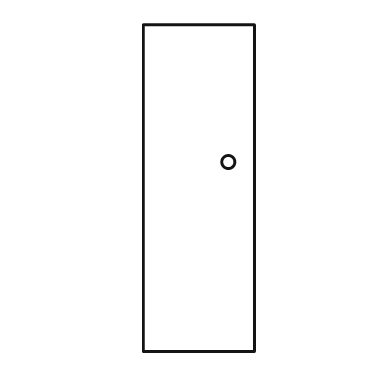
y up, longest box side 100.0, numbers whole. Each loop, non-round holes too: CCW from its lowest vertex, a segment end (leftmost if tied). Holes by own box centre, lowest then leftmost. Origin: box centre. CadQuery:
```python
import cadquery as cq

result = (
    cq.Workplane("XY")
    .moveTo(-17.0, -50.0)
    .lineTo(17.0, -50.0)
    .lineTo(17.0, 50.0)
    .lineTo(-17.0, 50.0)
    .close()
    .moveTo(9.0, 8.0)
    .circle(2.0)
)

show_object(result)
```